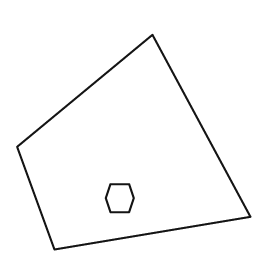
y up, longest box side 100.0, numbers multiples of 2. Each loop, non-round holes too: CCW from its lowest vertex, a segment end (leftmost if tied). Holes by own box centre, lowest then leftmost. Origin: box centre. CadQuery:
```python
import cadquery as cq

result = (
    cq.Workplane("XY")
    .moveTo(-34.0, -46.0)
    .lineTo(50.0, -32.0)
    .lineTo(8.0, 46.0)
    .lineTo(-50.0, -2.0)
    .close()
    .moveTo(-10.0, -30.0)
    .lineTo(-2.0, -30.0)
    .lineTo(0.0, -24.0)
    .lineTo(-2.0, -18.0)
    .lineTo(-10.0, -18.0)
    .lineTo(-12.0, -24.0)
    .close()
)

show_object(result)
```